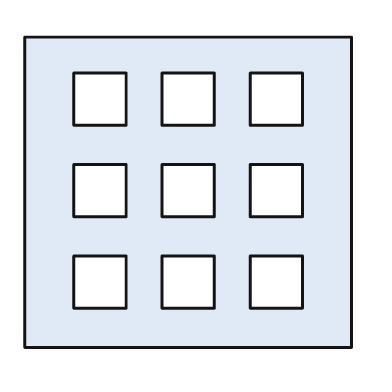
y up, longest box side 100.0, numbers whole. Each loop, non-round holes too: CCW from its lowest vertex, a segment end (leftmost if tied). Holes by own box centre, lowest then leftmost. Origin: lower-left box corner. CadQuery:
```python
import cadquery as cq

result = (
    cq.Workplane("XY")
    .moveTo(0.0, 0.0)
    .lineTo(100.0, 0.0)
    .lineTo(100.0, 95.0)
    .lineTo(0.0, 95.0)
    .close()
    .moveTo(15.0, 12.0)
    .lineTo(31.0, 12.0)
    .lineTo(31.0, 28.0)
    .lineTo(15.0, 28.0)
    .close()
    .moveTo(42.0, 12.0)
    .lineTo(58.0, 12.0)
    .lineTo(58.0, 28.0)
    .lineTo(42.0, 28.0)
    .close()
    .moveTo(69.0, 12.0)
    .lineTo(85.0, 12.0)
    .lineTo(85.0, 28.0)
    .lineTo(69.0, 28.0)
    .close()
    .moveTo(15.0, 40.0)
    .lineTo(31.0, 40.0)
    .lineTo(31.0, 56.0)
    .lineTo(15.0, 56.0)
    .close()
    .moveTo(42.0, 40.0)
    .lineTo(58.0, 40.0)
    .lineTo(58.0, 56.0)
    .lineTo(42.0, 56.0)
    .close()
    .moveTo(69.0, 40.0)
    .lineTo(85.0, 40.0)
    .lineTo(85.0, 56.0)
    .lineTo(69.0, 56.0)
    .close()
    .moveTo(15.0, 68.0)
    .lineTo(31.0, 68.0)
    .lineTo(31.0, 84.0)
    .lineTo(15.0, 84.0)
    .close()
    .moveTo(42.0, 68.0)
    .lineTo(58.0, 68.0)
    .lineTo(58.0, 84.0)
    .lineTo(42.0, 84.0)
    .close()
    .moveTo(69.0, 68.0)
    .lineTo(85.0, 68.0)
    .lineTo(85.0, 84.0)
    .lineTo(69.0, 84.0)
    .close()
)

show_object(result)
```